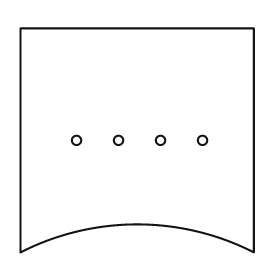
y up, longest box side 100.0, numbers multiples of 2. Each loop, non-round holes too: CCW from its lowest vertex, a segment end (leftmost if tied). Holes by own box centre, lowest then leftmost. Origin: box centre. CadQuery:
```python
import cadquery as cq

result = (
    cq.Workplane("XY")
    .moveTo(-50.0, -48.0)
    .threePointArc((0.0, -36.0), (50.0, -48.0))
    .lineTo(50.0, 48.0)
    .lineTo(-50.0, 48.0)
    .close()
    .moveTo(-26.0, 0.0)
    .circle(2.0)
    .moveTo(-8.0, 0.0)
    .circle(2.0)
    .moveTo(10.0, 0.0)
    .circle(2.0)
    .moveTo(28.0, 0.0)
    .circle(2.0)
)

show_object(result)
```